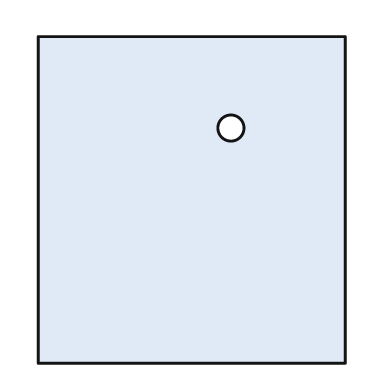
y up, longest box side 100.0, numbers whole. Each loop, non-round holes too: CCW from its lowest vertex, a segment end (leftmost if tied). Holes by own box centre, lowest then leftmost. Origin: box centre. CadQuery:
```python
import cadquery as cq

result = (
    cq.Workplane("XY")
    .moveTo(-47.0, -50.0)
    .lineTo(47.0, -50.0)
    .lineTo(47.0, 50.0)
    .lineTo(-47.0, 50.0)
    .close()
    .moveTo(12.0, 22.0)
    .circle(4.0)
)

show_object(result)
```